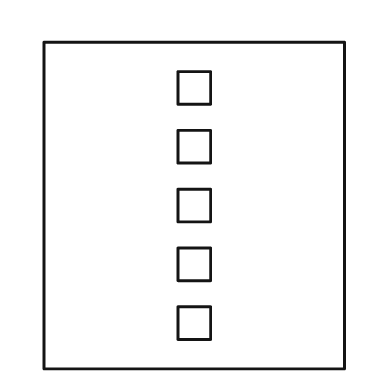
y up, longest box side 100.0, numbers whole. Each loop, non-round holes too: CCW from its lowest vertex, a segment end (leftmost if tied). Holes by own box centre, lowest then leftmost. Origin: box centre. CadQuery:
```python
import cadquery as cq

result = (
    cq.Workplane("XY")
    .moveTo(-46.0, -50.0)
    .lineTo(46.0, -50.0)
    .lineTo(46.0, 50.0)
    .lineTo(-46.0, 50.0)
    .close()
    .moveTo(-5.0, -41.0)
    .lineTo(5.0, -41.0)
    .lineTo(5.0, -31.0)
    .lineTo(-5.0, -31.0)
    .close()
    .moveTo(-5.0, -23.0)
    .lineTo(5.0, -23.0)
    .lineTo(5.0, -13.0)
    .lineTo(-5.0, -13.0)
    .close()
    .moveTo(-5.0, -5.0)
    .lineTo(5.0, -5.0)
    .lineTo(5.0, 5.0)
    .lineTo(-5.0, 5.0)
    .close()
    .moveTo(-5.0, 13.0)
    .lineTo(5.0, 13.0)
    .lineTo(5.0, 23.0)
    .lineTo(-5.0, 23.0)
    .close()
    .moveTo(-5.0, 31.0)
    .lineTo(5.0, 31.0)
    .lineTo(5.0, 41.0)
    .lineTo(-5.0, 41.0)
    .close()
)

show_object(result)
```